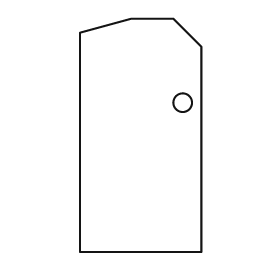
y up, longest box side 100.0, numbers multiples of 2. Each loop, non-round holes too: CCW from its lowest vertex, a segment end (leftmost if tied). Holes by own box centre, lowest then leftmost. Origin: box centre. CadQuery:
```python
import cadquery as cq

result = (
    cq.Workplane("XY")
    .moveTo(-26.0, -50.0)
    .lineTo(26.0, -50.0)
    .lineTo(26.0, 38.0)
    .lineTo(14.0, 50.0)
    .lineTo(-4.0, 50.0)
    .lineTo(-26.0, 44.0)
    .close()
    .moveTo(18.0, 14.0)
    .circle(4.0)
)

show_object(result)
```